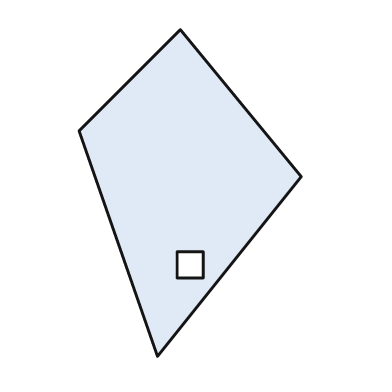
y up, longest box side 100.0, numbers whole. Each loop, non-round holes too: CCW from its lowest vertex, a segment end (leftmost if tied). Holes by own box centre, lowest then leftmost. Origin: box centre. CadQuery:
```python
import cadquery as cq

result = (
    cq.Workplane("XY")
    .moveTo(-10.0, -50.0)
    .lineTo(34.0, 5.0)
    .lineTo(-3.0, 50.0)
    .lineTo(-34.0, 19.0)
    .close()
    .moveTo(-4.0, -26.0)
    .lineTo(4.0, -26.0)
    .lineTo(4.0, -18.0)
    .lineTo(-4.0, -18.0)
    .close()
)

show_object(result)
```